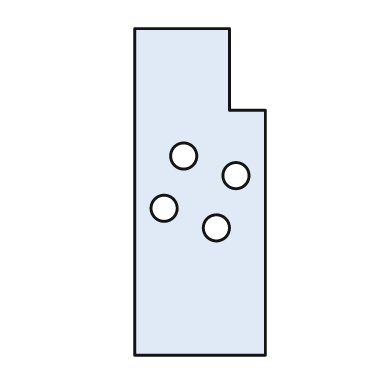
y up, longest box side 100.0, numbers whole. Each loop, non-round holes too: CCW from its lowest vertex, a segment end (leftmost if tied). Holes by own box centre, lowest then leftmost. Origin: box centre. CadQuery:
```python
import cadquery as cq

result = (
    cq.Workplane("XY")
    .moveTo(-20.0, -50.0)
    .lineTo(20.0, -50.0)
    .lineTo(20.0, 25.0)
    .lineTo(9.0, 25.0)
    .lineTo(9.0, 50.0)
    .lineTo(-20.0, 50.0)
    .close()
    .moveTo(5.0, -11.0)
    .circle(4.0)
    .moveTo(-11.0, -5.0)
    .circle(4.0)
    .moveTo(11.0, 5.0)
    .circle(4.0)
    .moveTo(-5.0, 11.0)
    .circle(4.0)
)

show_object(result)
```